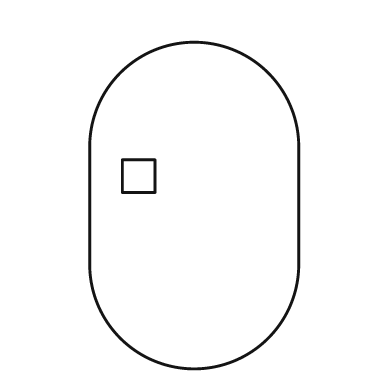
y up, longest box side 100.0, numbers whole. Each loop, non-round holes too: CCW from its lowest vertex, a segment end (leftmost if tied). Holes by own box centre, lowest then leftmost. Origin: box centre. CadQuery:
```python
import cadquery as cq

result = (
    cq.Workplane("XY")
    .moveTo(-32.0, -18.0)
    .threePointArc((0.0, -50.0), (32.0, -18.0))
    .lineTo(32.0, 18.0)
    .threePointArc((0.0, 50.0), (-32.0, 18.0))
    .close()
    .moveTo(-22.0, 4.0)
    .lineTo(-12.0, 4.0)
    .lineTo(-12.0, 14.0)
    .lineTo(-22.0, 14.0)
    .close()
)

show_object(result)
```